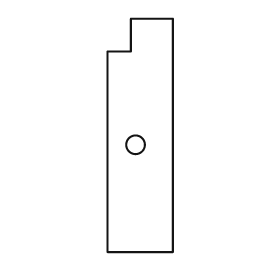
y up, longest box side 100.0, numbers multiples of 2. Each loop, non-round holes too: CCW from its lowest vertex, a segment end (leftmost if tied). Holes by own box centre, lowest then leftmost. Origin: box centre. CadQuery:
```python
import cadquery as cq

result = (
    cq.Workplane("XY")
    .moveTo(-14.0, -50.0)
    .lineTo(14.0, -50.0)
    .lineTo(14.0, 50.0)
    .lineTo(-4.0, 50.0)
    .lineTo(-4.0, 36.0)
    .lineTo(-14.0, 36.0)
    .close()
    .moveTo(-2.0, -4.0)
    .circle(4.0)
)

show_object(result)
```